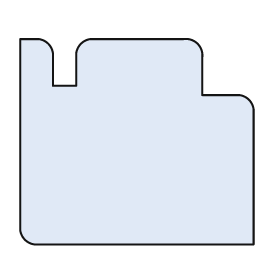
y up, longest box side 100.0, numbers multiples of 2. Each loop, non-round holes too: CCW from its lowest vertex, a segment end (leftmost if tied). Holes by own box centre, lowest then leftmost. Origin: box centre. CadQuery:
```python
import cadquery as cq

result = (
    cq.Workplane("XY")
    .moveTo(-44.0, -44.0)
    .lineTo(50.0, -44.0)
    .lineTo(50.0, 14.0)
    .threePointArc((48.0, 18.0), (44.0, 20.0))
    .lineTo(28.0, 20.0)
    .lineTo(28.0, 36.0)
    .threePointArc((26.0, 42.0), (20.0, 44.0))
    .lineTo(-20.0, 44.0)
    .threePointArc((-24.0, 42.0), (-26.0, 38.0))
    .lineTo(-26.0, 24.0)
    .lineTo(-36.0, 24.0)
    .lineTo(-36.0, 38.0)
    .threePointArc((-38.0, 42.0), (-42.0, 44.0))
    .lineTo(-50.0, 44.0)
    .lineTo(-50.0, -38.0)
    .threePointArc((-48.0, -42.0), (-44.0, -44.0))
    .close()
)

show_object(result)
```